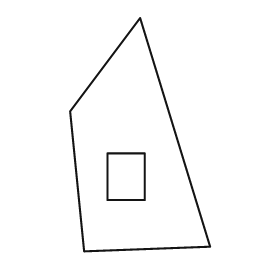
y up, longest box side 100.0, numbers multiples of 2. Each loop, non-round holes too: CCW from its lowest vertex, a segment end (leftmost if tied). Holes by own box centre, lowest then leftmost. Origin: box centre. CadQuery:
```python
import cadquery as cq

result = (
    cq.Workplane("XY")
    .moveTo(-24.0, -50.0)
    .lineTo(30.0, -48.0)
    .lineTo(0.0, 50.0)
    .lineTo(-30.0, 10.0)
    .close()
    .moveTo(-14.0, -28.0)
    .lineTo(2.0, -28.0)
    .lineTo(2.0, -8.0)
    .lineTo(-14.0, -8.0)
    .close()
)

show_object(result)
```